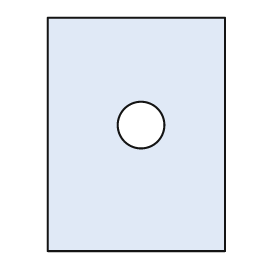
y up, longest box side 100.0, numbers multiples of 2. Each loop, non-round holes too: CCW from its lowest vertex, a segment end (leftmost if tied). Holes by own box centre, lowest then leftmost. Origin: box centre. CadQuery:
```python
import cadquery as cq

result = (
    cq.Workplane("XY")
    .moveTo(-38.0, -50.0)
    .lineTo(38.0, -50.0)
    .lineTo(38.0, 50.0)
    .lineTo(-38.0, 50.0)
    .close()
    .moveTo(2.0, 4.0)
    .circle(10.0)
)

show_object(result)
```